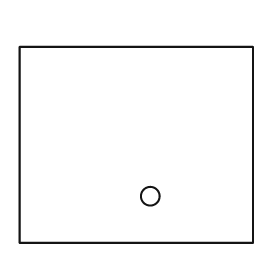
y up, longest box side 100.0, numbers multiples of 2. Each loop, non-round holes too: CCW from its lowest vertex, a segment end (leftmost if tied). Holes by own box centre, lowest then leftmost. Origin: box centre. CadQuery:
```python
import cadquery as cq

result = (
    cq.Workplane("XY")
    .moveTo(-50.0, -42.0)
    .lineTo(50.0, -42.0)
    .lineTo(50.0, 42.0)
    .lineTo(-50.0, 42.0)
    .close()
    .moveTo(6.0, -22.0)
    .circle(4.0)
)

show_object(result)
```